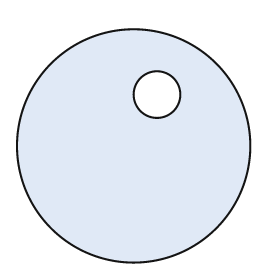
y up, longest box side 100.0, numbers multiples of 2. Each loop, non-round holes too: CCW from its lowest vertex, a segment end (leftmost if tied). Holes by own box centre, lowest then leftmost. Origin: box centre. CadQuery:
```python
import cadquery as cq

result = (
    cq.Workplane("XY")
    .moveTo(0.0, 0.0)
    .circle(50.0)
    .moveTo(10.0, 22.0)
    .circle(10.0)
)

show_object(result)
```